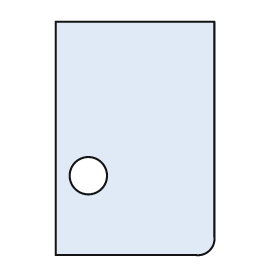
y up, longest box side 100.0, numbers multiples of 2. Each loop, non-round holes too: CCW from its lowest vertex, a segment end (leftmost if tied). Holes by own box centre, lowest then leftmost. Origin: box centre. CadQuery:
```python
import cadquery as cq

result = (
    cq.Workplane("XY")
    .moveTo(-34.0, -50.0)
    .lineTo(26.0, -50.0)
    .threePointArc((32.0, -48.0), (34.0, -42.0))
    .lineTo(34.0, 50.0)
    .lineTo(-34.0, 50.0)
    .close()
    .moveTo(-20.0, -16.0)
    .circle(8.0)
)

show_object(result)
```